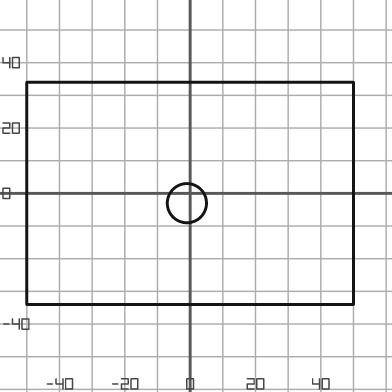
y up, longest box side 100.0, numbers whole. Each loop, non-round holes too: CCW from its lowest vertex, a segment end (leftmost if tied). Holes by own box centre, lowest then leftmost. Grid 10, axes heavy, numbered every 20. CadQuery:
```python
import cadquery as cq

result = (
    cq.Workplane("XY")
    .moveTo(-50.0, -34.0)
    .lineTo(50.0, -34.0)
    .lineTo(50.0, 34.0)
    .lineTo(-50.0, 34.0)
    .close()
    .moveTo(-1.0, -3.0)
    .circle(6.0)
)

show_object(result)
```